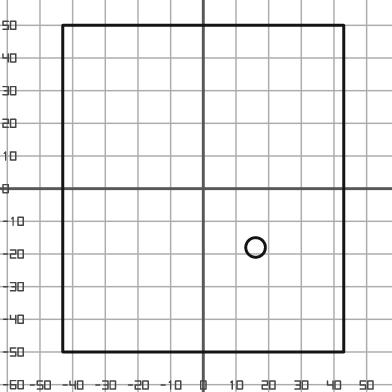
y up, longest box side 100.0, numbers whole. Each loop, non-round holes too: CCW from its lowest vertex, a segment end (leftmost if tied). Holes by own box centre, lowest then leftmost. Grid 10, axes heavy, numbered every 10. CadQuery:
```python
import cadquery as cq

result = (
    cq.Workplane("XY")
    .moveTo(-43.0, -50.0)
    .lineTo(43.0, -50.0)
    .lineTo(43.0, 50.0)
    .lineTo(-43.0, 50.0)
    .close()
    .moveTo(16.0, -18.0)
    .circle(3.0)
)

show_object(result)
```